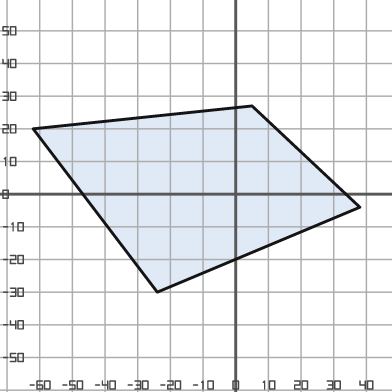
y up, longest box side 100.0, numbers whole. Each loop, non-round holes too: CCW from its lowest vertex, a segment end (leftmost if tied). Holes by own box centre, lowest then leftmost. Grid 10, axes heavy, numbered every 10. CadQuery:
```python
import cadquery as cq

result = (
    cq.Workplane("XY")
    .moveTo(-24.0, -30.0)
    .lineTo(38.0, -4.0)
    .lineTo(5.0, 27.0)
    .lineTo(-62.0, 20.0)
    .close()
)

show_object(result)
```